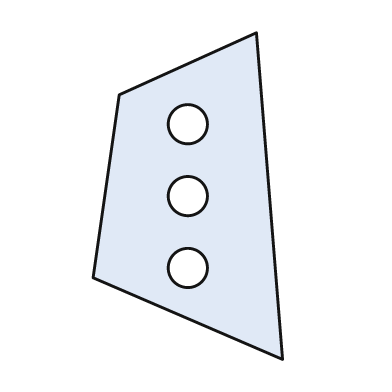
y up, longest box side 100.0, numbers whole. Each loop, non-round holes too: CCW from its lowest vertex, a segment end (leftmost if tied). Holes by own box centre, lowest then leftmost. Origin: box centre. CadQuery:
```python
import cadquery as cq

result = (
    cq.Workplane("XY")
    .moveTo(29.0, -50.0)
    .lineTo(21.0, 50.0)
    .lineTo(-21.0, 31.0)
    .lineTo(-29.0, -25.0)
    .close()
    .moveTo(0.0, -22.0)
    .circle(6.0)
    .moveTo(0.0, 0.0)
    .circle(6.0)
    .moveTo(0.0, 22.0)
    .circle(6.0)
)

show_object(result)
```